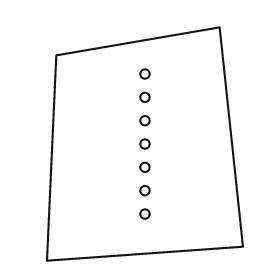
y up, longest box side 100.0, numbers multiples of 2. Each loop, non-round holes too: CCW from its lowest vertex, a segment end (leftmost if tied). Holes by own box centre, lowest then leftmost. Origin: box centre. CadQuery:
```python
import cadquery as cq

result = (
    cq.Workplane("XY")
    .moveTo(-42.0, -50.0)
    .lineTo(42.0, -44.0)
    .lineTo(32.0, 50.0)
    .lineTo(-38.0, 38.0)
    .close()
    .moveTo(0.0, -30.0)
    .circle(2.0)
    .moveTo(0.0, -20.0)
    .circle(2.0)
    .moveTo(0.0, -10.0)
    .circle(2.0)
    .moveTo(0.0, 0.0)
    .circle(2.0)
    .moveTo(0.0, 10.0)
    .circle(2.0)
    .moveTo(0.0, 20.0)
    .circle(2.0)
    .moveTo(0.0, 30.0)
    .circle(2.0)
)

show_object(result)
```